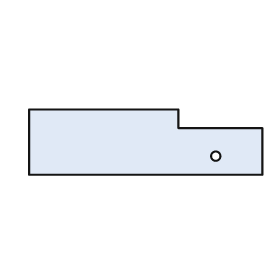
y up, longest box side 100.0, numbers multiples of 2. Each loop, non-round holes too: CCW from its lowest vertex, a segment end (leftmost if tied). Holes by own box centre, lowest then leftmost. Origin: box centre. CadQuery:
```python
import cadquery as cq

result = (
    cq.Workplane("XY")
    .moveTo(-50.0, -14.0)
    .lineTo(50.0, -14.0)
    .lineTo(50.0, 6.0)
    .lineTo(14.0, 6.0)
    .lineTo(14.0, 14.0)
    .lineTo(-50.0, 14.0)
    .close()
    .moveTo(30.0, -6.0)
    .circle(2.0)
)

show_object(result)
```